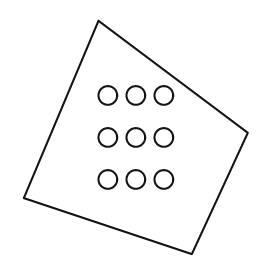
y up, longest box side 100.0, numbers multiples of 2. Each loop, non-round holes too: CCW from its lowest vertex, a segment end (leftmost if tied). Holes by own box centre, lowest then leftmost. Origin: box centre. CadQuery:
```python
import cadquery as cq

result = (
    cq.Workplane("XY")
    .moveTo(24.0, -50.0)
    .lineTo(48.0, 2.0)
    .lineTo(-16.0, 50.0)
    .lineTo(-48.0, -26.0)
    .close()
    .moveTo(-12.0, -18.0)
    .circle(4.0)
    .moveTo(0.0, -18.0)
    .circle(4.0)
    .moveTo(12.0, -18.0)
    .circle(4.0)
    .moveTo(-12.0, 0.0)
    .circle(4.0)
    .moveTo(0.0, 0.0)
    .circle(4.0)
    .moveTo(12.0, 0.0)
    .circle(4.0)
    .moveTo(-12.0, 18.0)
    .circle(4.0)
    .moveTo(0.0, 18.0)
    .circle(4.0)
    .moveTo(12.0, 18.0)
    .circle(4.0)
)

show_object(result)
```